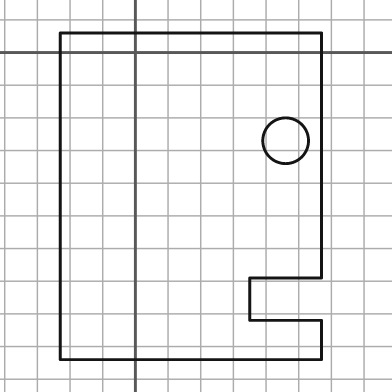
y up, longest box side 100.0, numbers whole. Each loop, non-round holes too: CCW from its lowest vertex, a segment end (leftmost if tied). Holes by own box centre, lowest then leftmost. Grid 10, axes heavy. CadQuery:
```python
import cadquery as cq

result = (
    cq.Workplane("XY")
    .moveTo(-23.0, -94.0)
    .lineTo(57.0, -94.0)
    .lineTo(57.0, -82.0)
    .lineTo(35.0, -82.0)
    .lineTo(35.0, -69.0)
    .lineTo(57.0, -69.0)
    .lineTo(57.0, 6.0)
    .lineTo(-23.0, 6.0)
    .close()
    .moveTo(46.0, -27.0)
    .circle(7.0)
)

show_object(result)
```